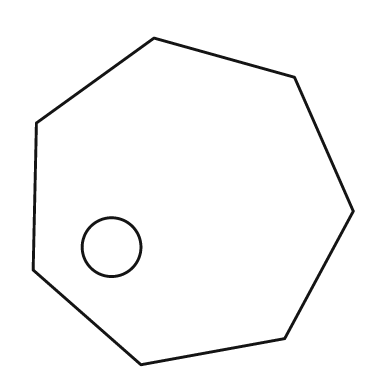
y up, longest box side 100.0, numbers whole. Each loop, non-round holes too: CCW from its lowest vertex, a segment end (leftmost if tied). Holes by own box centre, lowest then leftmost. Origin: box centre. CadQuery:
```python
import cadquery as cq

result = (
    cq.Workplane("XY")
    .moveTo(-16.0, -50.0)
    .lineTo(28.0, -42.0)
    .lineTo(49.0, -3.0)
    .lineTo(31.0, 38.0)
    .lineTo(-12.0, 50.0)
    .lineTo(-48.0, 24.0)
    .lineTo(-49.0, -21.0)
    .close()
    .moveTo(-25.0, -14.0)
    .circle(9.0)
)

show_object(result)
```